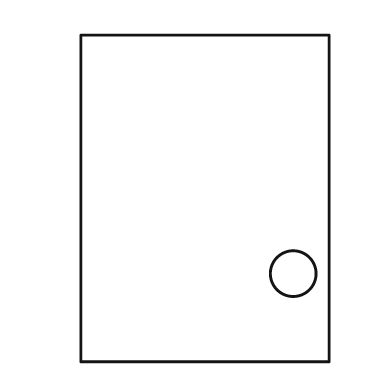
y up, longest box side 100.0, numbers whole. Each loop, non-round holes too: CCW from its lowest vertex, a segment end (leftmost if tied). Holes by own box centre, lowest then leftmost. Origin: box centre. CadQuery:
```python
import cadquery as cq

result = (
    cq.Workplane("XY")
    .moveTo(-38.0, -50.0)
    .lineTo(38.0, -50.0)
    .lineTo(38.0, 50.0)
    .lineTo(-38.0, 50.0)
    .close()
    .moveTo(27.0, -23.0)
    .circle(7.0)
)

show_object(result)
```